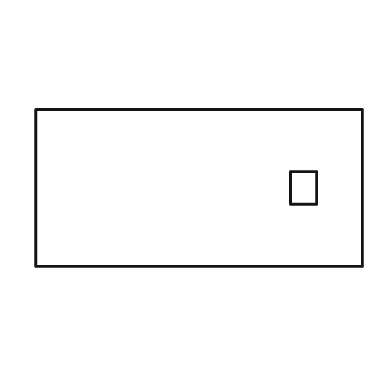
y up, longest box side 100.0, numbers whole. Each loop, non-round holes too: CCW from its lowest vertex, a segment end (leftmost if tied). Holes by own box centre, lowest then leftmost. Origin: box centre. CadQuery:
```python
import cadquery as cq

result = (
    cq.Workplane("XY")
    .moveTo(-50.0, -24.0)
    .lineTo(50.0, -24.0)
    .lineTo(50.0, 24.0)
    .lineTo(-50.0, 24.0)
    .close()
    .moveTo(28.0, -5.0)
    .lineTo(36.0, -5.0)
    .lineTo(36.0, 5.0)
    .lineTo(28.0, 5.0)
    .close()
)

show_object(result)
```